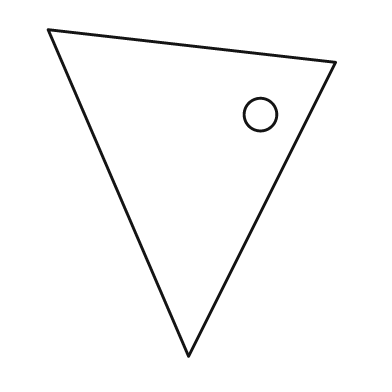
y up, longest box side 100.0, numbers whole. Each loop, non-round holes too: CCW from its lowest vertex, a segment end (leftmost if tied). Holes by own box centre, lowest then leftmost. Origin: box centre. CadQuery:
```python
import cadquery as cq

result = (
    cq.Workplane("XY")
    .moveTo(-1.0, -50.0)
    .lineTo(44.0, 40.0)
    .lineTo(-44.0, 50.0)
    .close()
    .moveTo(21.0, 24.0)
    .circle(5.0)
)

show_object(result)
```